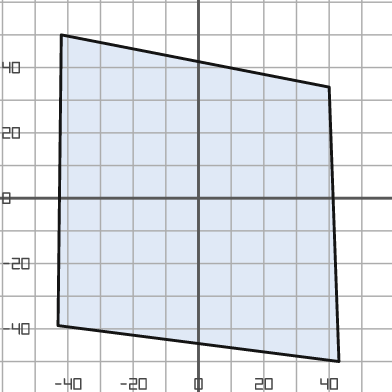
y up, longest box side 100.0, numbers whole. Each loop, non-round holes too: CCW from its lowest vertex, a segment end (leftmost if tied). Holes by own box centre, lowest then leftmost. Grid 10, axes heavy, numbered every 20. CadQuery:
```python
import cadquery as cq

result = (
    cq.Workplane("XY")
    .moveTo(43.0, -50.0)
    .lineTo(40.0, 34.0)
    .lineTo(-42.0, 50.0)
    .lineTo(-43.0, -39.0)
    .close()
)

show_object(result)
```